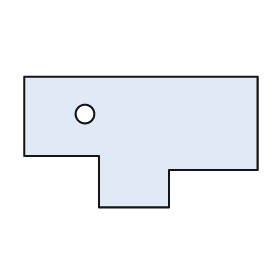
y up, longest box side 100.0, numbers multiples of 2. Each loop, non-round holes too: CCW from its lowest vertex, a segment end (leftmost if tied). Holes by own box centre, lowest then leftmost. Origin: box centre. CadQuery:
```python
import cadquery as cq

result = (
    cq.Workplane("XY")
    .moveTo(-18.0, -28.0)
    .lineTo(12.0, -28.0)
    .lineTo(12.0, -12.0)
    .lineTo(50.0, -12.0)
    .lineTo(50.0, 28.0)
    .lineTo(-50.0, 28.0)
    .lineTo(-50.0, -6.0)
    .lineTo(-18.0, -6.0)
    .close()
    .moveTo(-24.0, 12.0)
    .circle(4.0)
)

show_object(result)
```